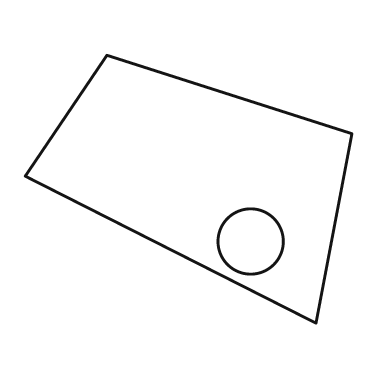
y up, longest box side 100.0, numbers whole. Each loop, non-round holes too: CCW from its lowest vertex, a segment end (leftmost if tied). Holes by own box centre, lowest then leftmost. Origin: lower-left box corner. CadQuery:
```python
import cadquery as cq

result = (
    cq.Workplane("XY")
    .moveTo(89.0, 0.0)
    .lineTo(100.0, 58.0)
    .lineTo(25.0, 82.0)
    .lineTo(0.0, 45.0)
    .close()
    .moveTo(69.0, 25.0)
    .circle(10.0)
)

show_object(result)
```